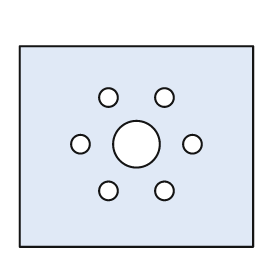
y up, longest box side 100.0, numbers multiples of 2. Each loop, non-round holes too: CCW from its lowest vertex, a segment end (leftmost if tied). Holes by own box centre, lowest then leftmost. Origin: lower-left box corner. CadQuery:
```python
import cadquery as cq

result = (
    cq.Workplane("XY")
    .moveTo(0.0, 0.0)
    .lineTo(100.0, 0.0)
    .lineTo(100.0, 86.0)
    .lineTo(0.0, 86.0)
    .close()
    .moveTo(38.0, 24.0)
    .circle(4.0)
    .moveTo(62.0, 24.0)
    .circle(4.0)
    .moveTo(26.0, 44.0)
    .circle(4.0)
    .moveTo(50.0, 44.0)
    .circle(10.0)
    .moveTo(74.0, 44.0)
    .circle(4.0)
    .moveTo(38.0, 64.0)
    .circle(4.0)
    .moveTo(62.0, 64.0)
    .circle(4.0)
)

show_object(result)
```